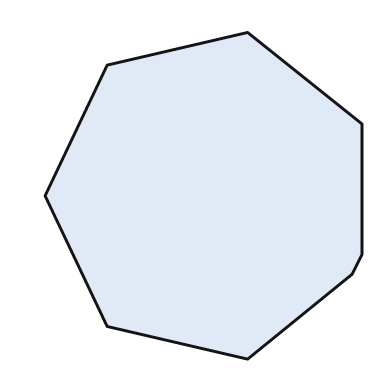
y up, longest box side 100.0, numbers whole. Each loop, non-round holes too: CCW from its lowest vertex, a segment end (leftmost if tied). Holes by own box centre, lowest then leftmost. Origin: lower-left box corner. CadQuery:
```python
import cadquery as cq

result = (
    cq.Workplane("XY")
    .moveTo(62.0, 0.0)
    .lineTo(94.0, 26.0)
    .lineTo(97.0, 32.0)
    .lineTo(97.0, 72.0)
    .lineTo(62.0, 100.0)
    .lineTo(19.0, 90.0)
    .lineTo(0.0, 50.0)
    .lineTo(19.0, 10.0)
    .close()
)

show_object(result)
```